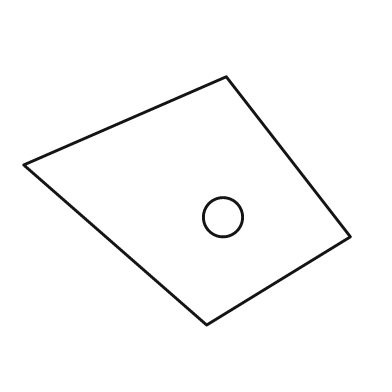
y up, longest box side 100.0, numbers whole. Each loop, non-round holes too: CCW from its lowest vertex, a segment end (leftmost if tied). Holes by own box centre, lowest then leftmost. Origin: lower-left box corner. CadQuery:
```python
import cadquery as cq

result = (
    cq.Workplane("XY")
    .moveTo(56.0, 0.0)
    .lineTo(100.0, 27.0)
    .lineTo(62.0, 76.0)
    .lineTo(0.0, 49.0)
    .close()
    .moveTo(61.0, 33.0)
    .circle(6.0)
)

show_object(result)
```